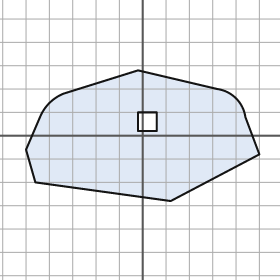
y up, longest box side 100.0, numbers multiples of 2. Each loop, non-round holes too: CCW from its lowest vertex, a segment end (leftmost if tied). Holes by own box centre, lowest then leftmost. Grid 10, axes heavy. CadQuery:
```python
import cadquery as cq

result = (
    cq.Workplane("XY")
    .moveTo(12.0, -28.0)
    .lineTo(50.0, -8.0)
    .lineTo(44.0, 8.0)
    .threePointArc((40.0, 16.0), (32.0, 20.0))
    .lineTo(-2.0, 28.0)
    .lineTo(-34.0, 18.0)
    .threePointArc((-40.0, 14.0), (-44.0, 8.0))
    .lineTo(-50.0, -6.0)
    .lineTo(-46.0, -20.0)
    .close()
    .moveTo(-2.0, 2.0)
    .lineTo(6.0, 2.0)
    .lineTo(6.0, 10.0)
    .lineTo(-2.0, 10.0)
    .close()
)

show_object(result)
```